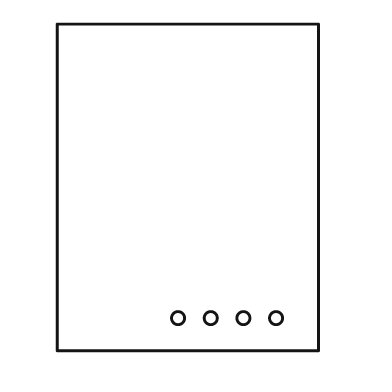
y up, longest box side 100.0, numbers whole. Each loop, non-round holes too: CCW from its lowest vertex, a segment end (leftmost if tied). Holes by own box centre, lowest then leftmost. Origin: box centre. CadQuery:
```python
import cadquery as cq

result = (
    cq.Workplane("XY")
    .moveTo(-40.0, -50.0)
    .lineTo(40.0, -50.0)
    .lineTo(40.0, 50.0)
    .lineTo(-40.0, 50.0)
    .close()
    .moveTo(-3.0, -40.0)
    .circle(2.0)
    .moveTo(7.0, -40.0)
    .circle(2.0)
    .moveTo(17.0, -40.0)
    .circle(2.0)
    .moveTo(27.0, -40.0)
    .circle(2.0)
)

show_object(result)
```